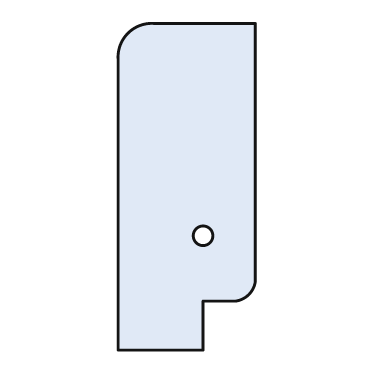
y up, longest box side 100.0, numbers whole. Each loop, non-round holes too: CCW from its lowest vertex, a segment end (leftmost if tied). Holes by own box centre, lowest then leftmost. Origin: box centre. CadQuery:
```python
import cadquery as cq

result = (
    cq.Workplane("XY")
    .moveTo(-21.0, -50.0)
    .lineTo(5.0, -50.0)
    .lineTo(5.0, -35.0)
    .lineTo(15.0, -35.0)
    .threePointArc((19.0, -33.0), (21.0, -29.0))
    .lineTo(21.0, 50.0)
    .lineTo(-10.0, 50.0)
    .threePointArc((-18.0, 47.0), (-21.0, 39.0))
    .close()
    .moveTo(5.0, -15.0)
    .circle(3.0)
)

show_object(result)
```